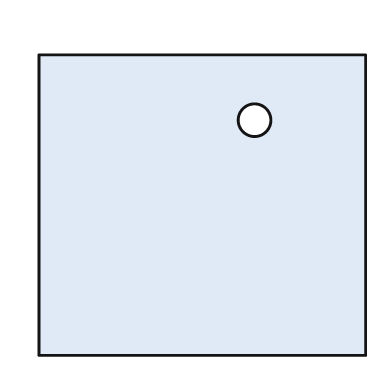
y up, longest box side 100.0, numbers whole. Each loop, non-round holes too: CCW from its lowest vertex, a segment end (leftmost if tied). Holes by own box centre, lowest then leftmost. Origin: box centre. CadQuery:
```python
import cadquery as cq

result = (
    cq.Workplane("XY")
    .moveTo(-50.0, -46.0)
    .lineTo(50.0, -46.0)
    .lineTo(50.0, 46.0)
    .lineTo(-50.0, 46.0)
    .close()
    .moveTo(16.0, 26.0)
    .circle(5.0)
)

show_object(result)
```